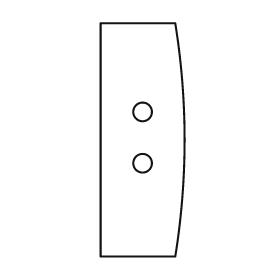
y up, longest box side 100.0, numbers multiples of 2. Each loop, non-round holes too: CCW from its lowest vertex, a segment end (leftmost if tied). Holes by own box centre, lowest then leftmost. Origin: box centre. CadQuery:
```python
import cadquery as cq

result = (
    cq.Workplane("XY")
    .moveTo(-18.0, -50.0)
    .lineTo(14.0, -50.0)
    .threePointArc((18.0, 0.0), (14.0, 50.0))
    .lineTo(-18.0, 50.0)
    .close()
    .moveTo(0.0, -10.0)
    .circle(4.0)
    .moveTo(0.0, 12.0)
    .circle(4.0)
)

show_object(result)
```